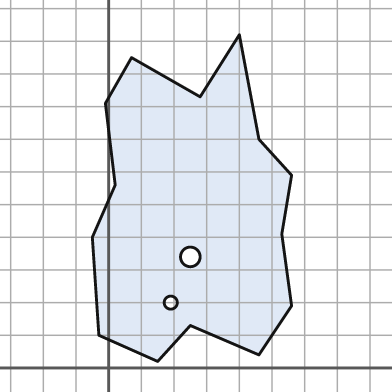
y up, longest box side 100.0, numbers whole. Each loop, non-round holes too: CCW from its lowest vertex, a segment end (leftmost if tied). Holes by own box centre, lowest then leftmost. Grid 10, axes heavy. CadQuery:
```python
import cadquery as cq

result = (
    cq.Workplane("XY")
    .moveTo(15.0, 2.0)
    .lineTo(25.0, 13.0)
    .lineTo(46.0, 4.0)
    .lineTo(56.0, 19.0)
    .lineTo(53.0, 41.0)
    .lineTo(56.0, 59.0)
    .lineTo(46.0, 70.0)
    .lineTo(40.0, 102.0)
    .lineTo(28.0, 83.0)
    .lineTo(7.0, 95.0)
    .lineTo(-1.0, 81.0)
    .lineTo(2.0, 56.0)
    .lineTo(-5.0, 40.0)
    .lineTo(-3.0, 10.0)
    .close()
    .moveTo(19.0, 20.0)
    .circle(2.0)
    .moveTo(25.0, 34.0)
    .circle(3.0)
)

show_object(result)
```